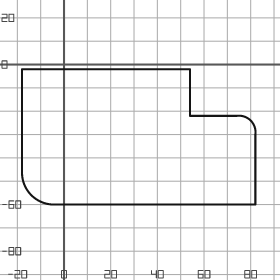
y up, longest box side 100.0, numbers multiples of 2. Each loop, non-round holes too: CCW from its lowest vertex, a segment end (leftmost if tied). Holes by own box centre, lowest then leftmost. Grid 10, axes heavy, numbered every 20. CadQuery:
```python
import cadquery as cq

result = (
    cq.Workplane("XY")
    .moveTo(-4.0, -60.0)
    .lineTo(82.0, -60.0)
    .lineTo(82.0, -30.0)
    .threePointArc((80.0, -24.0), (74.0, -22.0))
    .lineTo(54.0, -22.0)
    .lineTo(54.0, -2.0)
    .lineTo(-18.0, -2.0)
    .lineTo(-18.0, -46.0)
    .threePointArc((-14.0, -56.0), (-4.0, -60.0))
    .close()
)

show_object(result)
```